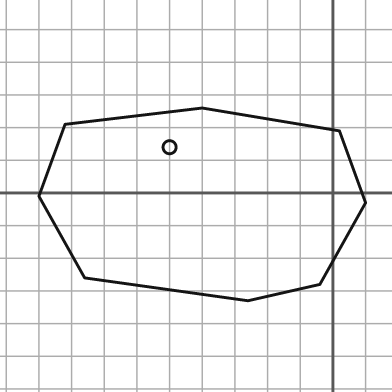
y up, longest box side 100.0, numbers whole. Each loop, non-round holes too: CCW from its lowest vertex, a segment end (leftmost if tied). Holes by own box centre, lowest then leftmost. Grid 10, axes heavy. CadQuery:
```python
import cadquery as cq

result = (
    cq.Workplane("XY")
    .moveTo(-26.0, -33.0)
    .lineTo(-4.0, -28.0)
    .lineTo(10.0, -3.0)
    .lineTo(2.0, 19.0)
    .lineTo(-40.0, 26.0)
    .lineTo(-82.0, 21.0)
    .lineTo(-90.0, -1.0)
    .lineTo(-76.0, -26.0)
    .close()
    .moveTo(-50.0, 14.0)
    .circle(2.0)
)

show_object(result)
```